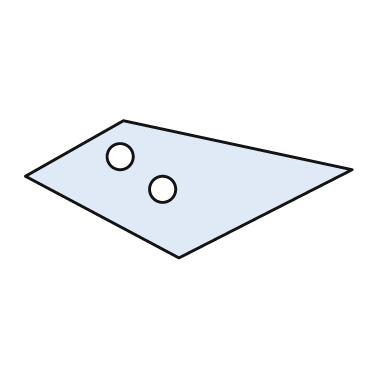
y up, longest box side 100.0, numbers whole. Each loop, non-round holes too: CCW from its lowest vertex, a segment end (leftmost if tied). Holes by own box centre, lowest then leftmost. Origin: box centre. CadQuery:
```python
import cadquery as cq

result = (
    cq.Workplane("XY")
    .moveTo(-3.0, -21.0)
    .lineTo(50.0, 6.0)
    .lineTo(-20.0, 21.0)
    .lineTo(-50.0, 4.0)
    .close()
    .moveTo(-8.0, 0.0)
    .circle(4.0)
    .moveTo(-21.0, 10.0)
    .circle(4.0)
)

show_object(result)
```